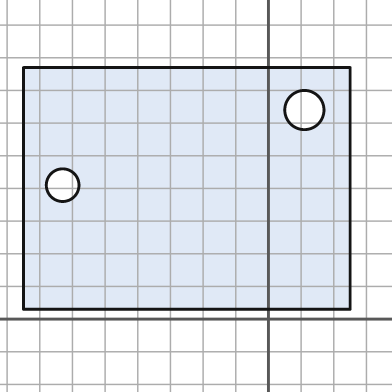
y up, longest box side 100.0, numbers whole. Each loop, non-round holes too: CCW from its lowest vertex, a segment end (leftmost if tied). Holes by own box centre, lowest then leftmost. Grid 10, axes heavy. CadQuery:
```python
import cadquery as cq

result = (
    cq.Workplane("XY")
    .moveTo(-75.0, 3.0)
    .lineTo(25.0, 3.0)
    .lineTo(25.0, 77.0)
    .lineTo(-75.0, 77.0)
    .close()
    .moveTo(-63.0, 41.0)
    .circle(5.0)
    .moveTo(11.0, 64.0)
    .circle(6.0)
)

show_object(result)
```